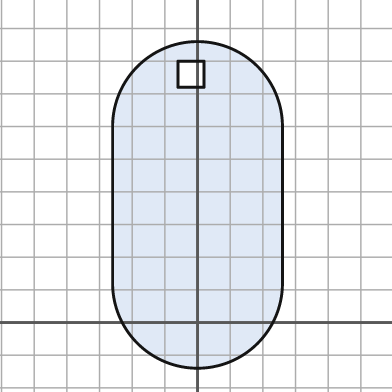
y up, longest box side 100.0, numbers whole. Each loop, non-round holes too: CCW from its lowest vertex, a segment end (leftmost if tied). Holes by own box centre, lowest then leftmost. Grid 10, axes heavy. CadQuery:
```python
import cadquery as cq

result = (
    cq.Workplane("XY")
    .moveTo(-26.0, 12.0)
    .threePointArc((0.0, -14.0), (26.0, 12.0))
    .lineTo(26.0, 60.0)
    .threePointArc((0.0, 86.0), (-26.0, 60.0))
    .close()
    .moveTo(-6.0, 72.0)
    .lineTo(2.0, 72.0)
    .lineTo(2.0, 80.0)
    .lineTo(-6.0, 80.0)
    .close()
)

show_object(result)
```